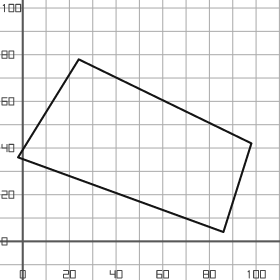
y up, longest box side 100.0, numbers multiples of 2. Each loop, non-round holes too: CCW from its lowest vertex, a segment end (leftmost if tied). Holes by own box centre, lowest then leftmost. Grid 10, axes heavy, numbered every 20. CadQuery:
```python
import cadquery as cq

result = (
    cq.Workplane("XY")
    .moveTo(86.0, 4.0)
    .lineTo(98.0, 42.0)
    .lineTo(24.0, 78.0)
    .lineTo(-2.0, 36.0)
    .close()
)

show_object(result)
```